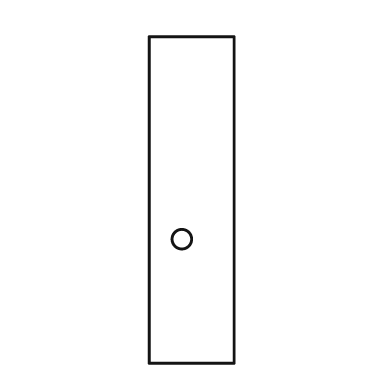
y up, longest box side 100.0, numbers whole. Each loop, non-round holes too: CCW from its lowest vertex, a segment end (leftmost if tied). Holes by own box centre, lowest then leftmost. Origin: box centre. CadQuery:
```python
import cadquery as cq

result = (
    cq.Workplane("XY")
    .moveTo(-13.0, -50.0)
    .lineTo(13.0, -50.0)
    .lineTo(13.0, 50.0)
    .lineTo(-13.0, 50.0)
    .close()
    .moveTo(-3.0, -12.0)
    .circle(3.0)
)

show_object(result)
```